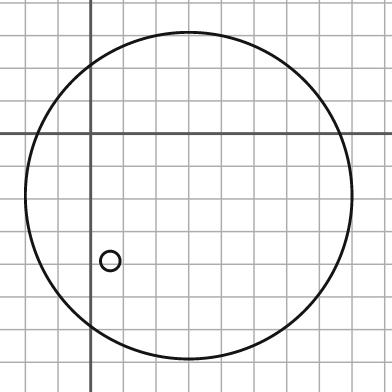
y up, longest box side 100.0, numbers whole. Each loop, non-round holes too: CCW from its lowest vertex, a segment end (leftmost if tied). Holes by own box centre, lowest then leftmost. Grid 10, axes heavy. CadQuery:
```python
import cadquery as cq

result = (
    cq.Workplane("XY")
    .moveTo(30.0, -19.0)
    .circle(50.0)
    .moveTo(6.0, -39.0)
    .circle(3.0)
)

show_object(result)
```